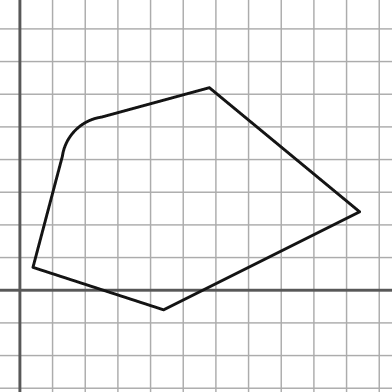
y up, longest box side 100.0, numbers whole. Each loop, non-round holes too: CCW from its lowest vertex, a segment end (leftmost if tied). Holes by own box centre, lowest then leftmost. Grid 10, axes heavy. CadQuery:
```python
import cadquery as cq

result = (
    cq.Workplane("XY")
    .moveTo(44.0, -6.0)
    .lineTo(104.0, 24.0)
    .lineTo(58.0, 62.0)
    .lineTo(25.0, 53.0)
    .threePointArc((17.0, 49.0), (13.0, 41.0))
    .lineTo(4.0, 7.0)
    .close()
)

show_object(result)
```